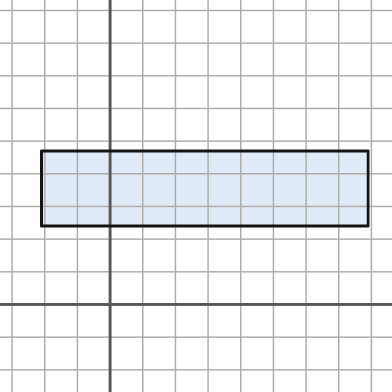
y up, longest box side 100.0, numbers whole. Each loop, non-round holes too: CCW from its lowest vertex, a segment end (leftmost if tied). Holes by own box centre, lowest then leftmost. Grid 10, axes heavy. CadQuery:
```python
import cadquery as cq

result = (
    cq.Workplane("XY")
    .moveTo(-21.0, 24.0)
    .lineTo(79.0, 24.0)
    .lineTo(79.0, 47.0)
    .lineTo(-21.0, 47.0)
    .close()
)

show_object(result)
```